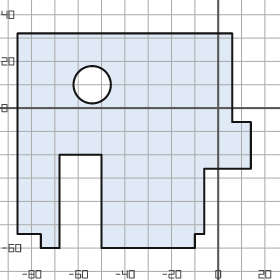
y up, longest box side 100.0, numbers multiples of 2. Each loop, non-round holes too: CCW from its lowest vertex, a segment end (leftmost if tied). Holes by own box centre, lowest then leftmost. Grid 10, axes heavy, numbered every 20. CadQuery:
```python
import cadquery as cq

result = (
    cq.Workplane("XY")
    .moveTo(-76.0, -60.0)
    .lineTo(-68.0, -60.0)
    .lineTo(-68.0, -20.0)
    .lineTo(-50.0, -20.0)
    .lineTo(-50.0, -60.0)
    .lineTo(-10.0, -60.0)
    .lineTo(-10.0, -54.0)
    .lineTo(-6.0, -54.0)
    .lineTo(-6.0, -26.0)
    .lineTo(14.0, -26.0)
    .lineTo(14.0, -6.0)
    .lineTo(6.0, -6.0)
    .lineTo(6.0, 32.0)
    .lineTo(-86.0, 32.0)
    .lineTo(-86.0, -54.0)
    .lineTo(-76.0, -54.0)
    .close()
    .moveTo(-54.0, 10.0)
    .circle(8.0)
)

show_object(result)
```